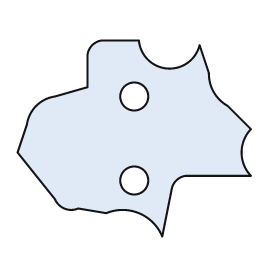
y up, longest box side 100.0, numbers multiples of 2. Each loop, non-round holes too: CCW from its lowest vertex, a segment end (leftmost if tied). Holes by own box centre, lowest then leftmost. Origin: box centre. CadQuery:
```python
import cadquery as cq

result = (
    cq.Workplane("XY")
    .moveTo(12.0, -42.0)
    .lineTo(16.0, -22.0)
    .threePointArc((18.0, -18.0), (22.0, -16.0))
    .lineTo(50.0, -16.0)
    .threePointArc((46.0, -6.0), (50.0, 4.0))
    .lineTo(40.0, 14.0)
    .threePointArc((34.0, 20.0), (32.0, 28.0))
    .lineTo(28.0, 40.0)
    .threePointArc((14.0, 30.0), (2.0, 42.0))
    .lineTo(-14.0, 42.0)
    .threePointArc((-18.0, 40.0), (-20.0, 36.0))
    .lineTo(-20.0, 22.0)
    .lineTo(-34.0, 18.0)
    .threePointArc((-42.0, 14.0), (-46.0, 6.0))
    .lineTo(-50.0, -6.0)
    .lineTo(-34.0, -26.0)
    .threePointArc((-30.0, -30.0), (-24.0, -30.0))
    .lineTo(-12.0, -32.0)
    .threePointArc((2.0, -32.0), (12.0, -42.0))
    .close()
    .moveTo(0.0, -18.0)
    .circle(6.0)
    .moveTo(0.0, 18.0)
    .circle(6.0)
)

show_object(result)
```